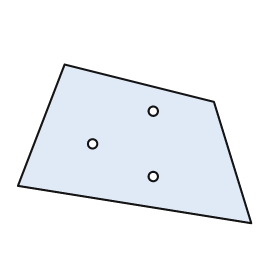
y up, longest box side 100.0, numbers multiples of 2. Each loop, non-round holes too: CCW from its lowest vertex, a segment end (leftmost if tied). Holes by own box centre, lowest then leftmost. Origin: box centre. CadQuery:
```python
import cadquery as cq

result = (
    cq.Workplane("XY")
    .moveTo(50.0, -34.0)
    .lineTo(34.0, 18.0)
    .lineTo(-30.0, 34.0)
    .lineTo(-50.0, -18.0)
    .close()
    .moveTo(8.0, -14.0)
    .circle(2.0)
    .moveTo(-18.0, 0.0)
    .circle(2.0)
    .moveTo(8.0, 14.0)
    .circle(2.0)
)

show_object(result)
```